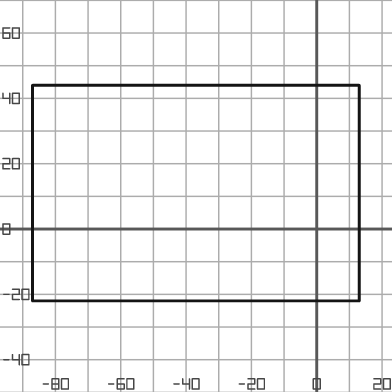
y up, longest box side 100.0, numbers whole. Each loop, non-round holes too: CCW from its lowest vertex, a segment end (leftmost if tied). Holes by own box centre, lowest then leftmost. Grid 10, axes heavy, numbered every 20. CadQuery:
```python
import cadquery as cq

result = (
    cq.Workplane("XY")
    .moveTo(-87.0, -22.0)
    .lineTo(13.0, -22.0)
    .lineTo(13.0, 44.0)
    .lineTo(-87.0, 44.0)
    .close()
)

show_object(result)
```